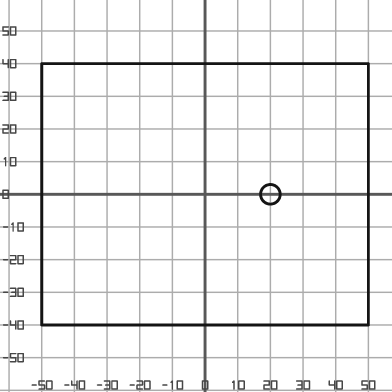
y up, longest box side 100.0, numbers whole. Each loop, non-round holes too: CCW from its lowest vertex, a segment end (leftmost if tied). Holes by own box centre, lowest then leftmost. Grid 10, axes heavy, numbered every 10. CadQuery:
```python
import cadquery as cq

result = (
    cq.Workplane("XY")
    .moveTo(-50.0, -40.0)
    .lineTo(50.0, -40.0)
    .lineTo(50.0, 40.0)
    .lineTo(-50.0, 40.0)
    .close()
    .moveTo(20.0, 0.0)
    .circle(3.0)
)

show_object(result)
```